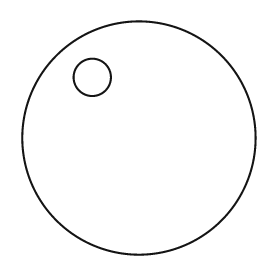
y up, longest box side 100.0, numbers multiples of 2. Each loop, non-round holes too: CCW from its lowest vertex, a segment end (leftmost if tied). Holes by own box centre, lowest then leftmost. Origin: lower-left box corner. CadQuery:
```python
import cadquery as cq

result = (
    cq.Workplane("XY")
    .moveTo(50.0, 50.0)
    .circle(50.0)
    .moveTo(30.0, 76.0)
    .circle(8.0)
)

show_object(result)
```